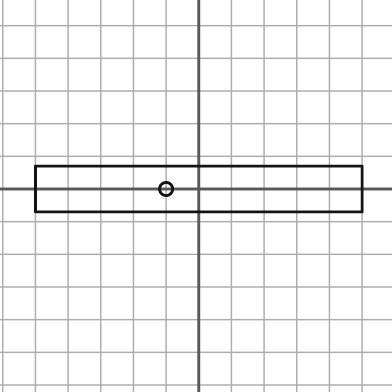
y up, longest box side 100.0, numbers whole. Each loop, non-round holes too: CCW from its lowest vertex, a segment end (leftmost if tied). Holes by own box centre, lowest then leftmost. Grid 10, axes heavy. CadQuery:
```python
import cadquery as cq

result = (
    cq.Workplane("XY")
    .moveTo(-50.0, -7.0)
    .lineTo(50.0, -7.0)
    .lineTo(50.0, 7.0)
    .lineTo(-50.0, 7.0)
    .close()
    .moveTo(-10.0, 0.0)
    .circle(2.0)
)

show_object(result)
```